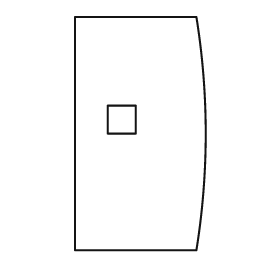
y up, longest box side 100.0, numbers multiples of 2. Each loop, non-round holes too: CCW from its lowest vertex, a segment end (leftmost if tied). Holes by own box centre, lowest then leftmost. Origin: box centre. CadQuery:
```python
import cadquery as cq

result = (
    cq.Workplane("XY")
    .moveTo(-28.0, -50.0)
    .lineTo(24.0, -50.0)
    .threePointArc((28.0, 0.0), (24.0, 50.0))
    .lineTo(-28.0, 50.0)
    .close()
    .moveTo(-14.0, 0.0)
    .lineTo(-2.0, 0.0)
    .lineTo(-2.0, 12.0)
    .lineTo(-14.0, 12.0)
    .close()
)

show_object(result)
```